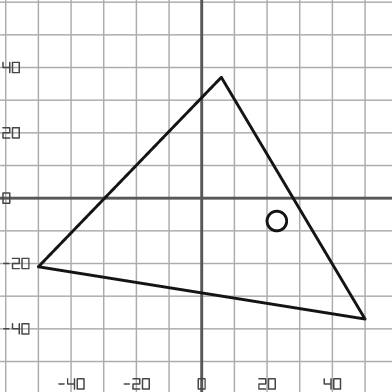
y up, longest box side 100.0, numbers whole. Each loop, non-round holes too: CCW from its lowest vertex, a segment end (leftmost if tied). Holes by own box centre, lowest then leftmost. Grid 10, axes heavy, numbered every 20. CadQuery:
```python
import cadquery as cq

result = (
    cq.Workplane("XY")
    .moveTo(50.0, -37.0)
    .lineTo(6.0, 37.0)
    .lineTo(-50.0, -21.0)
    .close()
    .moveTo(23.0, -7.0)
    .circle(3.0)
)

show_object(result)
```